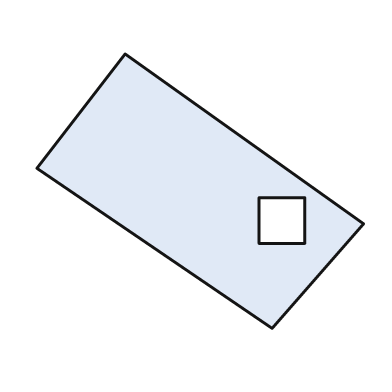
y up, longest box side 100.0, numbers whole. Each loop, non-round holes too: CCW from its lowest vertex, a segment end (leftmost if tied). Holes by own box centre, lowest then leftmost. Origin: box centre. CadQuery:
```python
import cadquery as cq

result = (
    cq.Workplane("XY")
    .moveTo(22.0, -42.0)
    .lineTo(50.0, -10.0)
    .lineTo(-23.0, 42.0)
    .lineTo(-50.0, 7.0)
    .close()
    .moveTo(18.0, -16.0)
    .lineTo(32.0, -16.0)
    .lineTo(32.0, -2.0)
    .lineTo(18.0, -2.0)
    .close()
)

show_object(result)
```